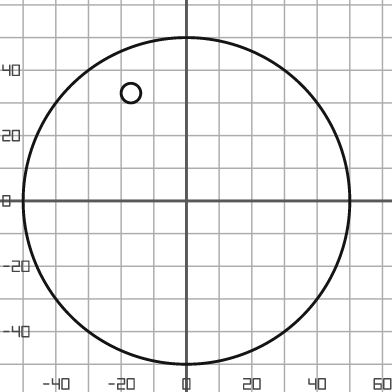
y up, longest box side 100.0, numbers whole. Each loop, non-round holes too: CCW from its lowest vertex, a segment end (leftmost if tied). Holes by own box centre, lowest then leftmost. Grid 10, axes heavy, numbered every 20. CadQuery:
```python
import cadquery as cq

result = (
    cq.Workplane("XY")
    .moveTo(0.0, 0.0)
    .circle(50.0)
    .moveTo(-17.0, 33.0)
    .circle(3.0)
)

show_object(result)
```